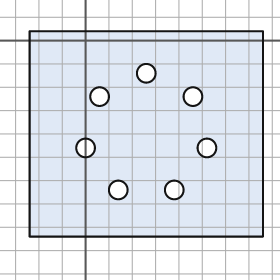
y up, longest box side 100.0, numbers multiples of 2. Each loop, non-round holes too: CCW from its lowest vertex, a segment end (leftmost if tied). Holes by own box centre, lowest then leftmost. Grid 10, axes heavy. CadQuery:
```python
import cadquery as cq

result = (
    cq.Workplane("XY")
    .moveTo(-24.0, -84.0)
    .lineTo(76.0, -84.0)
    .lineTo(76.0, 4.0)
    .lineTo(-24.0, 4.0)
    .close()
    .moveTo(14.0, -64.0)
    .circle(4.0)
    .moveTo(38.0, -64.0)
    .circle(4.0)
    .moveTo(0.0, -46.0)
    .circle(4.0)
    .moveTo(52.0, -46.0)
    .circle(4.0)
    .moveTo(6.0, -24.0)
    .circle(4.0)
    .moveTo(46.0, -24.0)
    .circle(4.0)
    .moveTo(26.0, -14.0)
    .circle(4.0)
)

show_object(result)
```